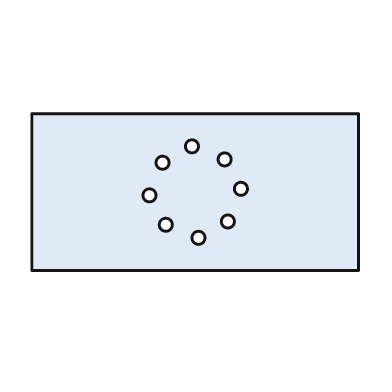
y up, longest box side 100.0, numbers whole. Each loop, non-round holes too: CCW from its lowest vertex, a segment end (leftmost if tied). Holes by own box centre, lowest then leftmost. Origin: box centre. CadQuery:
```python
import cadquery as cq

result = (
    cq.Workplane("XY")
    .moveTo(-50.0, -24.0)
    .lineTo(50.0, -24.0)
    .lineTo(50.0, 24.0)
    .lineTo(-50.0, 24.0)
    .close()
    .moveTo(1.0, -14.0)
    .circle(2.0)
    .moveTo(-9.0, -10.0)
    .circle(2.0)
    .moveTo(10.0, -9.0)
    .circle(2.0)
    .moveTo(-14.0, -1.0)
    .circle(2.0)
    .moveTo(14.0, 1.0)
    .circle(2.0)
    .moveTo(-10.0, 9.0)
    .circle(2.0)
    .moveTo(9.0, 10.0)
    .circle(2.0)
    .moveTo(-1.0, 14.0)
    .circle(2.0)
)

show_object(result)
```